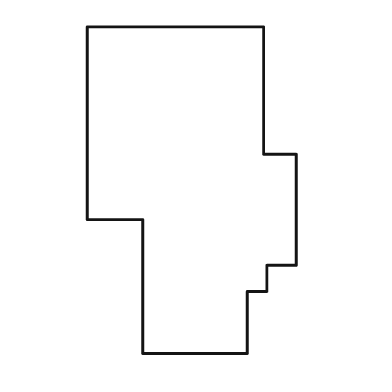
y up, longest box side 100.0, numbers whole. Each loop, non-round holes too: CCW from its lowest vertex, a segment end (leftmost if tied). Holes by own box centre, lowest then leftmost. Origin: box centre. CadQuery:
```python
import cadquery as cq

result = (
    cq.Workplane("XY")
    .moveTo(-15.0, -50.0)
    .lineTo(17.0, -50.0)
    .lineTo(17.0, -31.0)
    .lineTo(23.0, -31.0)
    .lineTo(23.0, -23.0)
    .lineTo(32.0, -23.0)
    .lineTo(32.0, 11.0)
    .lineTo(22.0, 11.0)
    .lineTo(22.0, 50.0)
    .lineTo(-32.0, 50.0)
    .lineTo(-32.0, -9.0)
    .lineTo(-15.0, -9.0)
    .close()
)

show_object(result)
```